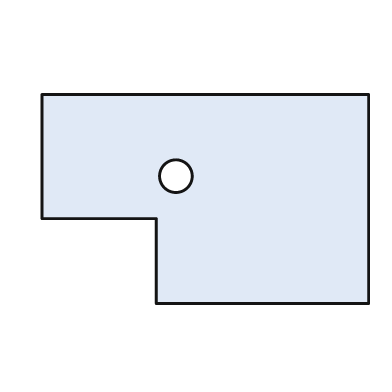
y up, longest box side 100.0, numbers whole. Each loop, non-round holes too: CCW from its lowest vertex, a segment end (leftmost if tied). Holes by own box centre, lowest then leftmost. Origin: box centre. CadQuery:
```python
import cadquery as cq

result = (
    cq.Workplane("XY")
    .moveTo(-15.0, -32.0)
    .lineTo(50.0, -32.0)
    .lineTo(50.0, 32.0)
    .lineTo(-50.0, 32.0)
    .lineTo(-50.0, -6.0)
    .lineTo(-15.0, -6.0)
    .close()
    .moveTo(-9.0, 7.0)
    .circle(5.0)
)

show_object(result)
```